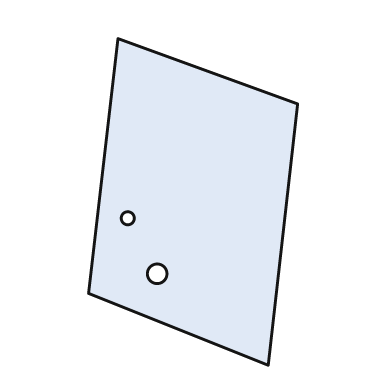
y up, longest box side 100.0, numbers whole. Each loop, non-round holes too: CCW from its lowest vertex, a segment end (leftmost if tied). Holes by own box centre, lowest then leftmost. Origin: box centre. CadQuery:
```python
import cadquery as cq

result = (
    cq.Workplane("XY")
    .moveTo(23.0, -50.0)
    .lineTo(32.0, 30.0)
    .lineTo(-23.0, 50.0)
    .lineTo(-32.0, -28.0)
    .close()
    .moveTo(-11.0, -22.0)
    .circle(3.0)
    .moveTo(-20.0, -5.0)
    .circle(2.0)
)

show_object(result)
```